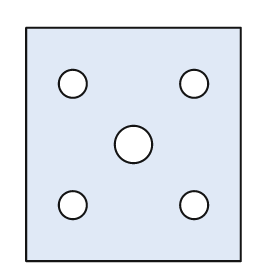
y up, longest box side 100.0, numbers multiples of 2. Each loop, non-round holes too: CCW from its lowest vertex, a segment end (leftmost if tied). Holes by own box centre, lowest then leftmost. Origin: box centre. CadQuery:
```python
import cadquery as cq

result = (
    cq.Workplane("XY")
    .moveTo(-46.0, -50.0)
    .lineTo(46.0, -50.0)
    .lineTo(46.0, 50.0)
    .lineTo(-46.0, 50.0)
    .close()
    .moveTo(-26.0, -26.0)
    .circle(6.0)
    .moveTo(26.0, -26.0)
    .circle(6.0)
    .moveTo(0.0, 0.0)
    .circle(8.0)
    .moveTo(-26.0, 26.0)
    .circle(6.0)
    .moveTo(26.0, 26.0)
    .circle(6.0)
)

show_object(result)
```